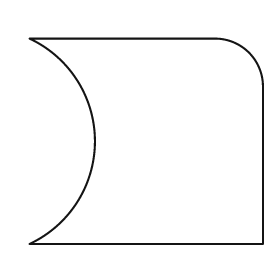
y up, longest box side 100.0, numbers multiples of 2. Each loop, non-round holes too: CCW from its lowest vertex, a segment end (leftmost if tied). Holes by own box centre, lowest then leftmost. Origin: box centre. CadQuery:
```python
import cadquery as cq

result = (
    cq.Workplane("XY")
    .moveTo(-50.0, -44.0)
    .lineTo(50.0, -44.0)
    .lineTo(50.0, 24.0)
    .threePointArc((44.0, 38.0), (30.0, 44.0))
    .lineTo(-50.0, 44.0)
    .threePointArc((-22.0, 0.0), (-50.0, -44.0))
    .close()
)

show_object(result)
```